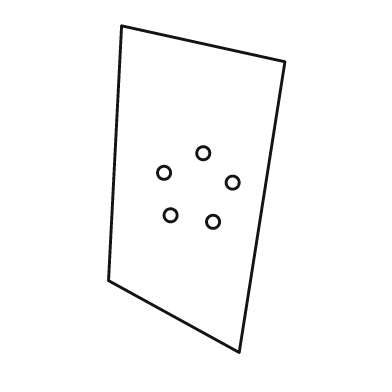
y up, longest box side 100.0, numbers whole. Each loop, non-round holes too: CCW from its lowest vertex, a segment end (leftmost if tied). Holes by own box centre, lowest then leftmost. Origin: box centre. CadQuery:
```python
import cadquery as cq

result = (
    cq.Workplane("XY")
    .moveTo(13.0, -50.0)
    .lineTo(27.0, 39.0)
    .lineTo(-23.0, 50.0)
    .lineTo(-27.0, -28.0)
    .close()
    .moveTo(5.0, -10.0)
    .circle(2.0)
    .moveTo(-8.0, -8.0)
    .circle(2.0)
    .moveTo(11.0, 2.0)
    .circle(2.0)
    .moveTo(-10.0, 5.0)
    .circle(2.0)
    .moveTo(2.0, 11.0)
    .circle(2.0)
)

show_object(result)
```